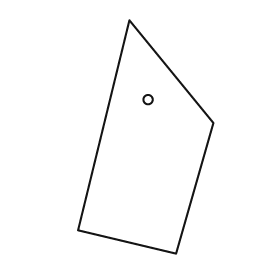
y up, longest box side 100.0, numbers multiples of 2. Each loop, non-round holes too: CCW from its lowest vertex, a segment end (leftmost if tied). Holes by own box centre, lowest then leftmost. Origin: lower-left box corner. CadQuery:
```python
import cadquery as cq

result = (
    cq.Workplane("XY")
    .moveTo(42.0, 0.0)
    .lineTo(58.0, 56.0)
    .lineTo(22.0, 100.0)
    .lineTo(0.0, 10.0)
    .close()
    .moveTo(30.0, 66.0)
    .circle(2.0)
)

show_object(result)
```